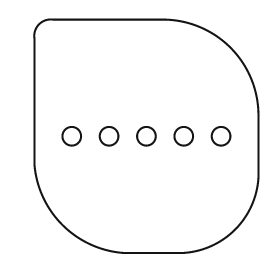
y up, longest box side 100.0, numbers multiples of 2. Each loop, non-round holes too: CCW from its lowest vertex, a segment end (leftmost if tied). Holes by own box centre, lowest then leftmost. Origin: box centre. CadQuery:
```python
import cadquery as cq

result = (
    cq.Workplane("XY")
    .moveTo(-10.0, -50.0)
    .lineTo(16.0, -50.0)
    .threePointArc((38.0, -40.0), (48.0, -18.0))
    .lineTo(48.0, 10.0)
    .threePointArc((36.0, 38.0), (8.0, 50.0))
    .lineTo(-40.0, 50.0)
    .threePointArc((-46.0, 48.0), (-48.0, 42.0))
    .lineTo(-48.0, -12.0)
    .threePointArc((-36.0, -38.0), (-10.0, -50.0))
    .close()
    .moveTo(-32.0, 0.0)
    .circle(4.0)
    .moveTo(-16.0, 0.0)
    .circle(4.0)
    .moveTo(0.0, 0.0)
    .circle(4.0)
    .moveTo(16.0, 0.0)
    .circle(4.0)
    .moveTo(32.0, 0.0)
    .circle(4.0)
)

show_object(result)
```